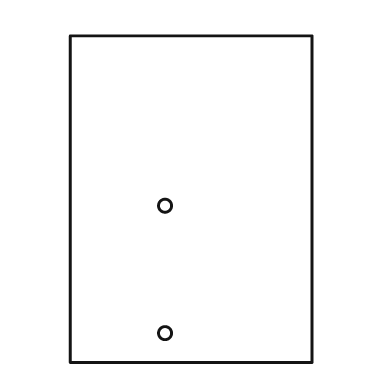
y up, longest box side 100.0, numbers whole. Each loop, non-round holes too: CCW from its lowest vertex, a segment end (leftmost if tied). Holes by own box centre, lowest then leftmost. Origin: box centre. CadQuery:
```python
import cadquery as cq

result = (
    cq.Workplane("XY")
    .moveTo(-37.0, -50.0)
    .lineTo(37.0, -50.0)
    .lineTo(37.0, 50.0)
    .lineTo(-37.0, 50.0)
    .close()
    .moveTo(-8.0, -41.0)
    .circle(2.0)
    .moveTo(-8.0, -2.0)
    .circle(2.0)
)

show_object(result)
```